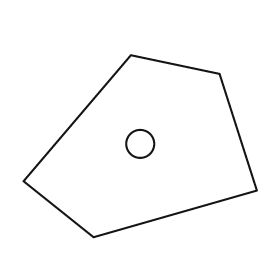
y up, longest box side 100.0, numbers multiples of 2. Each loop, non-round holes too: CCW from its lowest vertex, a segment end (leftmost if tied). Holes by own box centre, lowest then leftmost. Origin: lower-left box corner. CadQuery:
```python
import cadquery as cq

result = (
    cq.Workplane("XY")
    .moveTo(30.0, 0.0)
    .lineTo(100.0, 20.0)
    .lineTo(84.0, 70.0)
    .lineTo(46.0, 78.0)
    .lineTo(0.0, 24.0)
    .close()
    .moveTo(50.0, 40.0)
    .circle(6.0)
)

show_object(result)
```